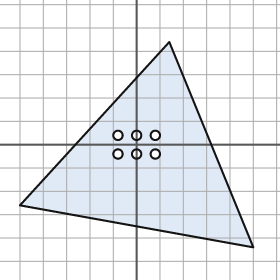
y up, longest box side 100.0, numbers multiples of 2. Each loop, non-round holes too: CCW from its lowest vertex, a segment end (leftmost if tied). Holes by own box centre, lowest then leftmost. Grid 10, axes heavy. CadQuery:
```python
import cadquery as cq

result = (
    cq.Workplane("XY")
    .moveTo(50.0, -44.0)
    .lineTo(14.0, 44.0)
    .lineTo(-50.0, -26.0)
    .close()
    .moveTo(-8.0, -4.0)
    .circle(2.0)
    .moveTo(0.0, -4.0)
    .circle(2.0)
    .moveTo(8.0, -4.0)
    .circle(2.0)
    .moveTo(-8.0, 4.0)
    .circle(2.0)
    .moveTo(0.0, 4.0)
    .circle(2.0)
    .moveTo(8.0, 4.0)
    .circle(2.0)
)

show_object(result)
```